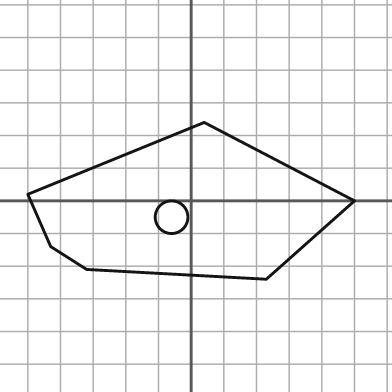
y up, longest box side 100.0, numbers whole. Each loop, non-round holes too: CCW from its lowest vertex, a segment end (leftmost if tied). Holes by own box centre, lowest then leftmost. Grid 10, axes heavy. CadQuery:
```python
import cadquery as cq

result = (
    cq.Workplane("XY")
    .moveTo(23.0, -24.0)
    .lineTo(50.0, 0.0)
    .lineTo(4.0, 24.0)
    .lineTo(-50.0, 2.0)
    .lineTo(-43.0, -14.0)
    .lineTo(-32.0, -21.0)
    .close()
    .moveTo(-6.0, -5.0)
    .circle(5.0)
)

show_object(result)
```